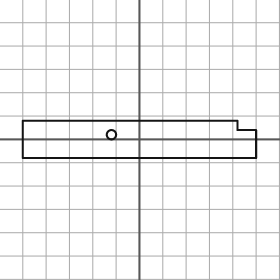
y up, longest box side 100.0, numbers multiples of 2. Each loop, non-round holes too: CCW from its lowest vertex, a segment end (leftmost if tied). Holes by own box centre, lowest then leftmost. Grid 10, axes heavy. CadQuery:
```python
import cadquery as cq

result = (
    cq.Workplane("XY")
    .moveTo(-50.0, -8.0)
    .lineTo(50.0, -8.0)
    .lineTo(50.0, 4.0)
    .lineTo(42.0, 4.0)
    .lineTo(42.0, 8.0)
    .lineTo(-50.0, 8.0)
    .close()
    .moveTo(-12.0, 2.0)
    .circle(2.0)
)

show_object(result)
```